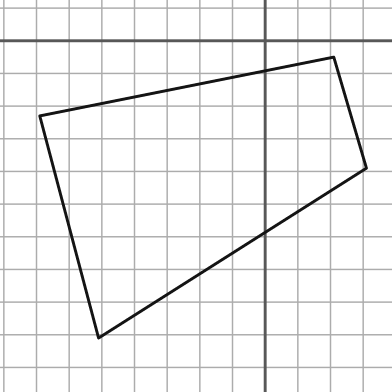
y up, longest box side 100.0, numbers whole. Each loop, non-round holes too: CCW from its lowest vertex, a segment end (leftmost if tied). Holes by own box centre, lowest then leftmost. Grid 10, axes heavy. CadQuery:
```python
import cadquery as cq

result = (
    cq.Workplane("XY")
    .moveTo(-51.0, -91.0)
    .lineTo(31.0, -39.0)
    .lineTo(21.0, -5.0)
    .lineTo(-69.0, -23.0)
    .close()
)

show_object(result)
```